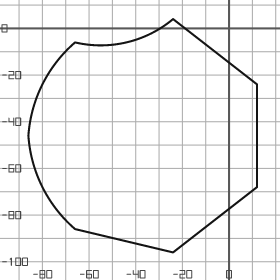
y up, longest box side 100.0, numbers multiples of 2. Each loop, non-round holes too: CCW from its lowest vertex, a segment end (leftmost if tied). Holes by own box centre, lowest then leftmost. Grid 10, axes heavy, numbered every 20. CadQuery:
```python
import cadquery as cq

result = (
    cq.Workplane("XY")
    .moveTo(-24.0, -96.0)
    .lineTo(12.0, -68.0)
    .lineTo(12.0, -24.0)
    .lineTo(-24.0, 4.0)
    .threePointArc((-44.0, -6.0), (-66.0, -6.0))
    .threePointArc((-80.0, -24.0), (-86.0, -46.0))
    .threePointArc((-80.0, -68.0), (-66.0, -86.0))
    .close()
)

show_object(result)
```